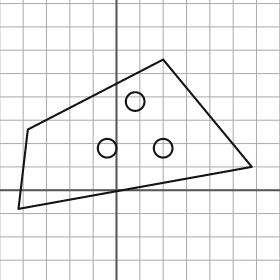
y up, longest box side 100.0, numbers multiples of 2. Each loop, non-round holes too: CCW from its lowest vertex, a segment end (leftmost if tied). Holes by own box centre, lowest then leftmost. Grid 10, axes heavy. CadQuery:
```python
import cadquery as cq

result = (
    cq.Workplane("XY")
    .moveTo(-42.0, -8.0)
    .lineTo(58.0, 10.0)
    .lineTo(20.0, 56.0)
    .lineTo(-38.0, 26.0)
    .close()
    .moveTo(-4.0, 18.0)
    .circle(4.0)
    .moveTo(20.0, 18.0)
    .circle(4.0)
    .moveTo(8.0, 38.0)
    .circle(4.0)
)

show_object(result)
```